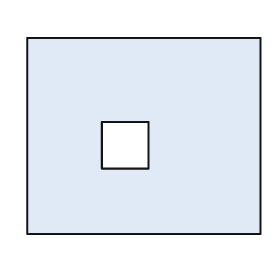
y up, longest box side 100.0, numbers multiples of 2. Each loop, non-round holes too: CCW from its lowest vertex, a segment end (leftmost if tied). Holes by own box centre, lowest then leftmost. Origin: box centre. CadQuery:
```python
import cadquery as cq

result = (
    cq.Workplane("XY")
    .moveTo(-50.0, -42.0)
    .lineTo(50.0, -42.0)
    .lineTo(50.0, 42.0)
    .lineTo(-50.0, 42.0)
    .close()
    .moveTo(-18.0, -14.0)
    .lineTo(2.0, -14.0)
    .lineTo(2.0, 6.0)
    .lineTo(-18.0, 6.0)
    .close()
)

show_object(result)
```